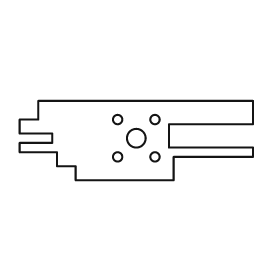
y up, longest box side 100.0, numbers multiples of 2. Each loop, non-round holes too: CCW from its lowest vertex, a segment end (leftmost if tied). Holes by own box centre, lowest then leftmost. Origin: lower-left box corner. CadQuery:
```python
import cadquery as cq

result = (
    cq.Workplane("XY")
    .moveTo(24.0, 0.0)
    .lineTo(66.0, 0.0)
    .lineTo(66.0, 10.0)
    .lineTo(100.0, 10.0)
    .lineTo(100.0, 14.0)
    .lineTo(64.0, 14.0)
    .lineTo(64.0, 24.0)
    .lineTo(100.0, 24.0)
    .lineTo(100.0, 34.0)
    .lineTo(8.0, 34.0)
    .lineTo(8.0, 26.0)
    .lineTo(0.0, 26.0)
    .lineTo(0.0, 20.0)
    .lineTo(14.0, 20.0)
    .lineTo(14.0, 16.0)
    .lineTo(0.0, 16.0)
    .lineTo(0.0, 12.0)
    .lineTo(16.0, 12.0)
    .lineTo(16.0, 6.0)
    .lineTo(24.0, 6.0)
    .close()
    .moveTo(42.0, 10.0)
    .circle(2.0)
    .moveTo(58.0, 10.0)
    .circle(2.0)
    .moveTo(50.0, 18.0)
    .circle(4.0)
    .moveTo(42.0, 26.0)
    .circle(2.0)
    .moveTo(58.0, 26.0)
    .circle(2.0)
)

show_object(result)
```